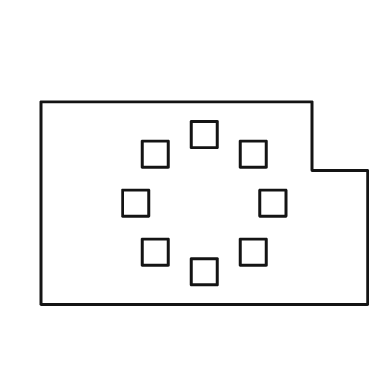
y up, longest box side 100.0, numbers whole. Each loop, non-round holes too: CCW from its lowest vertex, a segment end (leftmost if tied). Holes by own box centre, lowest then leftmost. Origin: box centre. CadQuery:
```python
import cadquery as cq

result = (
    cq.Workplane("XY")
    .moveTo(-50.0, -31.0)
    .lineTo(50.0, -31.0)
    .lineTo(50.0, 10.0)
    .lineTo(33.0, 10.0)
    .lineTo(33.0, 31.0)
    .lineTo(-50.0, 31.0)
    .close()
    .moveTo(-4.0, -25.0)
    .lineTo(4.0, -25.0)
    .lineTo(4.0, -17.0)
    .lineTo(-4.0, -17.0)
    .close()
    .moveTo(-19.0, -19.0)
    .lineTo(-11.0, -19.0)
    .lineTo(-11.0, -11.0)
    .lineTo(-19.0, -11.0)
    .close()
    .moveTo(11.0, -19.0)
    .lineTo(19.0, -19.0)
    .lineTo(19.0, -11.0)
    .lineTo(11.0, -11.0)
    .close()
    .moveTo(-25.0, -4.0)
    .lineTo(-17.0, -4.0)
    .lineTo(-17.0, 4.0)
    .lineTo(-25.0, 4.0)
    .close()
    .moveTo(17.0, -4.0)
    .lineTo(25.0, -4.0)
    .lineTo(25.0, 4.0)
    .lineTo(17.0, 4.0)
    .close()
    .moveTo(-19.0, 11.0)
    .lineTo(-11.0, 11.0)
    .lineTo(-11.0, 19.0)
    .lineTo(-19.0, 19.0)
    .close()
    .moveTo(11.0, 11.0)
    .lineTo(19.0, 11.0)
    .lineTo(19.0, 19.0)
    .lineTo(11.0, 19.0)
    .close()
    .moveTo(-4.0, 17.0)
    .lineTo(4.0, 17.0)
    .lineTo(4.0, 25.0)
    .lineTo(-4.0, 25.0)
    .close()
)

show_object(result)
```